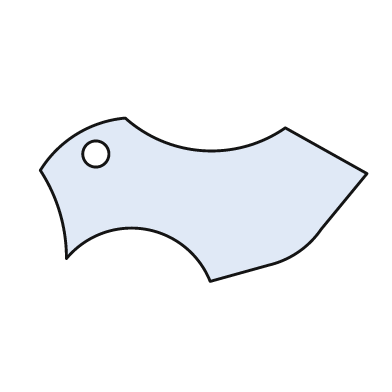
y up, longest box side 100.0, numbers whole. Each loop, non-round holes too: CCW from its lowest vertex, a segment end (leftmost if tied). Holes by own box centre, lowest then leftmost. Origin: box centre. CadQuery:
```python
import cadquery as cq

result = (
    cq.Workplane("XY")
    .moveTo(2.0, -25.0)
    .lineTo(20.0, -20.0)
    .threePointArc((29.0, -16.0), (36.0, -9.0))
    .lineTo(50.0, 8.0)
    .lineTo(25.0, 22.0)
    .threePointArc((0.0, 15.0), (-24.0, 25.0))
    .threePointArc((-39.0, 20.0), (-50.0, 9.0))
    .threePointArc((-44.0, -4.0), (-42.0, -18.0))
    .threePointArc((-18.0, -9.0), (2.0, -25.0))
    .close()
    .moveTo(-33.0, 14.0)
    .circle(4.0)
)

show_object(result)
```